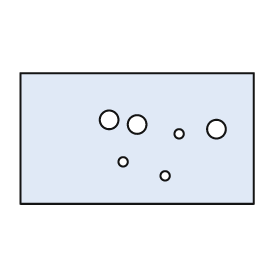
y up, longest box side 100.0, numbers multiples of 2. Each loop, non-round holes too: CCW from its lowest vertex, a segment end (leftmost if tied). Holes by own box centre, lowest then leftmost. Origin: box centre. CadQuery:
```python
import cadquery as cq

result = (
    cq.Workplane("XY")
    .moveTo(-50.0, -28.0)
    .lineTo(50.0, -28.0)
    .lineTo(50.0, 28.0)
    .lineTo(-50.0, 28.0)
    .close()
    .moveTo(12.0, -16.0)
    .circle(2.0)
    .moveTo(-6.0, -10.0)
    .circle(2.0)
    .moveTo(18.0, 2.0)
    .circle(2.0)
    .moveTo(34.0, 4.0)
    .circle(4.0)
    .moveTo(0.0, 6.0)
    .circle(4.0)
    .moveTo(-12.0, 8.0)
    .circle(4.0)
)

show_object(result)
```